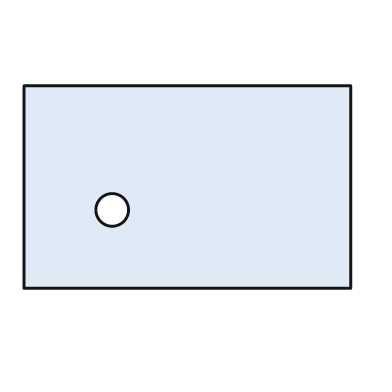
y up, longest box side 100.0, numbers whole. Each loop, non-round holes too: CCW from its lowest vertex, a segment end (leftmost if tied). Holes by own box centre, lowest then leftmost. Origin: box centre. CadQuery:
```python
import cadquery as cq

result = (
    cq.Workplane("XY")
    .moveTo(-50.0, -31.0)
    .lineTo(50.0, -31.0)
    .lineTo(50.0, 31.0)
    .lineTo(-50.0, 31.0)
    .close()
    .moveTo(-23.0, -7.0)
    .circle(5.0)
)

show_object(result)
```